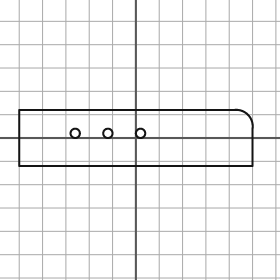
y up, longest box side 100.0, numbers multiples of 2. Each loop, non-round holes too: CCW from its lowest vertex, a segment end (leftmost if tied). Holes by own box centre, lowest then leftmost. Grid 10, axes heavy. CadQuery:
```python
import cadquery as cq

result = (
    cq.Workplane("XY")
    .moveTo(-50.0, -12.0)
    .lineTo(50.0, -12.0)
    .lineTo(50.0, 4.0)
    .threePointArc((48.0, 10.0), (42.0, 12.0))
    .lineTo(-50.0, 12.0)
    .close()
    .moveTo(-26.0, 2.0)
    .circle(2.0)
    .moveTo(-12.0, 2.0)
    .circle(2.0)
    .moveTo(2.0, 2.0)
    .circle(2.0)
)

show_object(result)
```